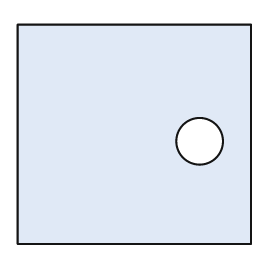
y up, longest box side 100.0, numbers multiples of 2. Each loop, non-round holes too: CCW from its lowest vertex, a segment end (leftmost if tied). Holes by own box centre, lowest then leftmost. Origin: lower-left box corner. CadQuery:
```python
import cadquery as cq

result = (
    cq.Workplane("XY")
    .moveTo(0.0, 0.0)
    .lineTo(100.0, 0.0)
    .lineTo(100.0, 94.0)
    .lineTo(0.0, 94.0)
    .close()
    .moveTo(78.0, 44.0)
    .circle(10.0)
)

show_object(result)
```